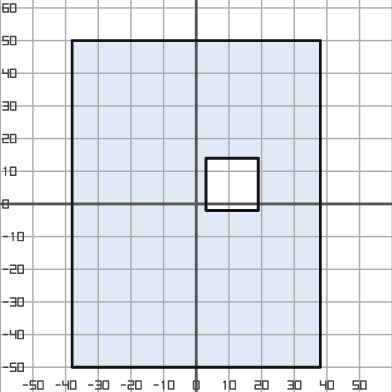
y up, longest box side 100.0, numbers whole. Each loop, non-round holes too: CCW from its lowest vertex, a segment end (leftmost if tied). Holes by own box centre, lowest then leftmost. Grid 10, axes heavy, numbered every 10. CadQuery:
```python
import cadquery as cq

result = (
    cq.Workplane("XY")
    .moveTo(-38.0, -50.0)
    .lineTo(38.0, -50.0)
    .lineTo(38.0, 50.0)
    .lineTo(-38.0, 50.0)
    .close()
    .moveTo(3.0, -2.0)
    .lineTo(19.0, -2.0)
    .lineTo(19.0, 14.0)
    .lineTo(3.0, 14.0)
    .close()
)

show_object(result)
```